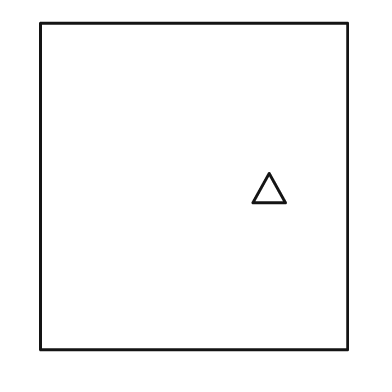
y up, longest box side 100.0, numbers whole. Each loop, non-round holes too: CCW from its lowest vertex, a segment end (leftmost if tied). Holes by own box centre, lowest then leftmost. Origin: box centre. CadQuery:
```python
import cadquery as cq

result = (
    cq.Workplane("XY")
    .moveTo(-47.0, -50.0)
    .lineTo(47.0, -50.0)
    .lineTo(47.0, 50.0)
    .lineTo(-47.0, 50.0)
    .close()
    .moveTo(18.0, -5.0)
    .lineTo(28.0, -5.0)
    .lineTo(23.0, 4.0)
    .close()
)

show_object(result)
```